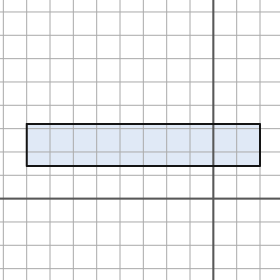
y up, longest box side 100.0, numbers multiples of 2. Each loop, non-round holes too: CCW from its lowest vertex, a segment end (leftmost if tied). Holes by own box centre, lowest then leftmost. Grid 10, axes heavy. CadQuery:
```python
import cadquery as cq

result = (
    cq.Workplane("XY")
    .moveTo(-80.0, 14.0)
    .lineTo(20.0, 14.0)
    .lineTo(20.0, 32.0)
    .lineTo(-80.0, 32.0)
    .close()
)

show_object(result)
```